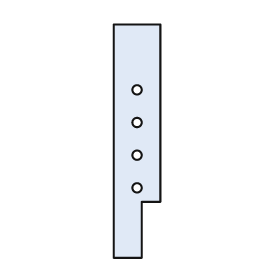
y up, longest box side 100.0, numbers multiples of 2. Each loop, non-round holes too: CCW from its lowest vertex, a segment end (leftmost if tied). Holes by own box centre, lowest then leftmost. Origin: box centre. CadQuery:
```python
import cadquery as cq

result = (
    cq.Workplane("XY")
    .moveTo(-10.0, -50.0)
    .lineTo(2.0, -50.0)
    .lineTo(2.0, -26.0)
    .lineTo(10.0, -26.0)
    .lineTo(10.0, 50.0)
    .lineTo(-10.0, 50.0)
    .close()
    .moveTo(0.0, -20.0)
    .circle(2.0)
    .moveTo(0.0, -6.0)
    .circle(2.0)
    .moveTo(0.0, 8.0)
    .circle(2.0)
    .moveTo(0.0, 22.0)
    .circle(2.0)
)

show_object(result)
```